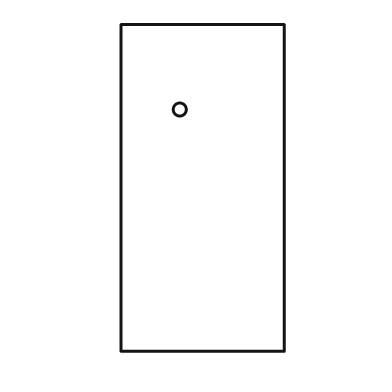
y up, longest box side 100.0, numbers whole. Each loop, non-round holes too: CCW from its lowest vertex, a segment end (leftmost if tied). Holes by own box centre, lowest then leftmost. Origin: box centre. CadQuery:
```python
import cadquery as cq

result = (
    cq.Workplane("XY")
    .moveTo(-25.0, -50.0)
    .lineTo(25.0, -50.0)
    .lineTo(25.0, 50.0)
    .lineTo(-25.0, 50.0)
    .close()
    .moveTo(-7.0, 24.0)
    .circle(2.0)
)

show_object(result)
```